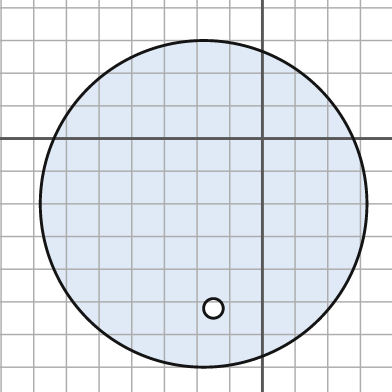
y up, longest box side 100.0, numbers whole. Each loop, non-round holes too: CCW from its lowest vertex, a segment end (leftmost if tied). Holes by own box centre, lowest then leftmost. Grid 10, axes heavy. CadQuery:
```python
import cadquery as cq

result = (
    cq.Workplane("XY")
    .moveTo(-18.0, -20.0)
    .circle(50.0)
    .moveTo(-15.0, -52.0)
    .circle(3.0)
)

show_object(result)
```